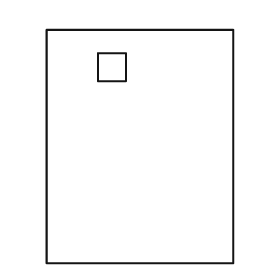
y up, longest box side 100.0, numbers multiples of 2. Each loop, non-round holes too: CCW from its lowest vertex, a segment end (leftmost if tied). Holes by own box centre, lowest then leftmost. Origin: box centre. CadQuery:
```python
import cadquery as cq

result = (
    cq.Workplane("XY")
    .moveTo(-40.0, -50.0)
    .lineTo(40.0, -50.0)
    .lineTo(40.0, 50.0)
    .lineTo(-40.0, 50.0)
    .close()
    .moveTo(-18.0, 28.0)
    .lineTo(-6.0, 28.0)
    .lineTo(-6.0, 40.0)
    .lineTo(-18.0, 40.0)
    .close()
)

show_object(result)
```